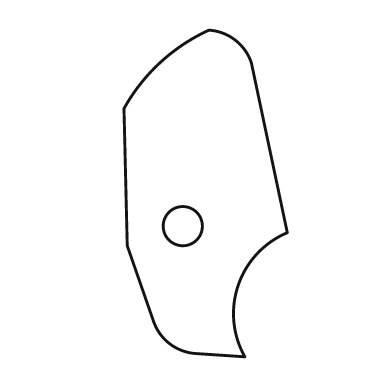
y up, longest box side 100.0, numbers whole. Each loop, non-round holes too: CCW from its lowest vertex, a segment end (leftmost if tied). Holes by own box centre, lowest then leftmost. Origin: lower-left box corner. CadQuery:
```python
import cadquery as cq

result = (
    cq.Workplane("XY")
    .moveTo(37.0, 0.0)
    .threePointArc((35.0, 22.0), (50.0, 38.0))
    .lineTo(39.0, 90.0)
    .threePointArc((34.0, 97.0), (26.0, 100.0))
    .threePointArc((11.0, 90.0), (0.0, 76.0))
    .lineTo(1.0, 34.0)
    .lineTo(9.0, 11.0)
    .threePointArc((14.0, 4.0), (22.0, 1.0))
    .close()
    .moveTo(18.0, 40.0)
    .circle(6.0)
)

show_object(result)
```